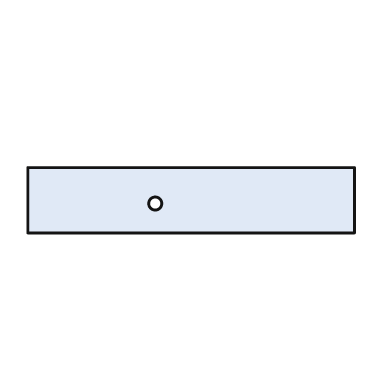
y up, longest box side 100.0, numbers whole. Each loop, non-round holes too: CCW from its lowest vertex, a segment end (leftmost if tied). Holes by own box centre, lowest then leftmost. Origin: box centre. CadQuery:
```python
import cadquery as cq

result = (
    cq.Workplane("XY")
    .moveTo(-50.0, -10.0)
    .lineTo(50.0, -10.0)
    .lineTo(50.0, 10.0)
    .lineTo(-50.0, 10.0)
    .close()
    .moveTo(-11.0, -1.0)
    .circle(2.0)
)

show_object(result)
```